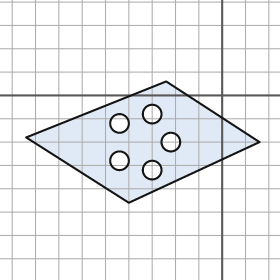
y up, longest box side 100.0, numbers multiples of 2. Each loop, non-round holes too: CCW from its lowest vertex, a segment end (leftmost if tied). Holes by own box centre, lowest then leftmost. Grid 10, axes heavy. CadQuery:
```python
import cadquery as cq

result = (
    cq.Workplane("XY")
    .moveTo(-40.0, -46.0)
    .lineTo(16.0, -20.0)
    .lineTo(-24.0, 6.0)
    .lineTo(-84.0, -18.0)
    .close()
    .moveTo(-30.0, -32.0)
    .circle(4.0)
    .moveTo(-44.0, -28.0)
    .circle(4.0)
    .moveTo(-22.0, -20.0)
    .circle(4.0)
    .moveTo(-44.0, -12.0)
    .circle(4.0)
    .moveTo(-30.0, -8.0)
    .circle(4.0)
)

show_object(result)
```